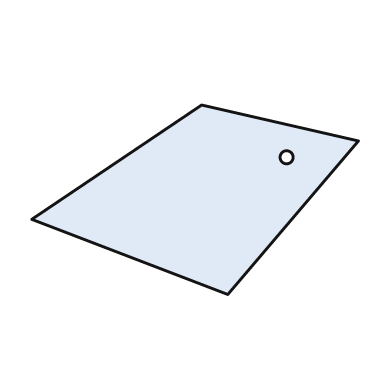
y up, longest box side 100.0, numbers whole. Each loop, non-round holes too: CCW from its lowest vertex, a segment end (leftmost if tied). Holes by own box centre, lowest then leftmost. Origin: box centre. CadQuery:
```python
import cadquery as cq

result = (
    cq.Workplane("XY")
    .moveTo(10.0, -29.0)
    .lineTo(50.0, 18.0)
    .lineTo(2.0, 29.0)
    .lineTo(-50.0, -6.0)
    .close()
    .moveTo(28.0, 13.0)
    .circle(2.0)
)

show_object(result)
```